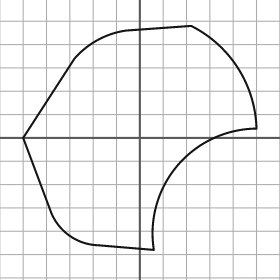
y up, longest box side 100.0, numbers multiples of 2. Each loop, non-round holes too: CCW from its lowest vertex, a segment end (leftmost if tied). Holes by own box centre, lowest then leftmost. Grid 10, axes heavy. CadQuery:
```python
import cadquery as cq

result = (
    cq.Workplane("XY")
    .moveTo(6.0, -48.0)
    .threePointArc((16.0, -12.0), (50.0, 4.0))
    .threePointArc((42.0, 30.0), (22.0, 48.0))
    .lineTo(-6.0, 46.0)
    .threePointArc((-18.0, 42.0), (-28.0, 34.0))
    .lineTo(-50.0, 0.0)
    .lineTo(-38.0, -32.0)
    .threePointArc((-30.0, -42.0), (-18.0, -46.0))
    .close()
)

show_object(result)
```